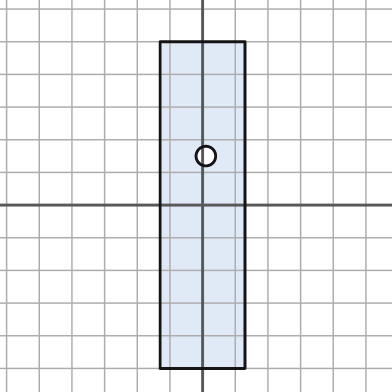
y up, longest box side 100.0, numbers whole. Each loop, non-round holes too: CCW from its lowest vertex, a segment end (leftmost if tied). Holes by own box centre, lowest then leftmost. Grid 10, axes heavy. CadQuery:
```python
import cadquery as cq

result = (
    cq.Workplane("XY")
    .moveTo(-13.0, -50.0)
    .lineTo(13.0, -50.0)
    .lineTo(13.0, 50.0)
    .lineTo(-13.0, 50.0)
    .close()
    .moveTo(1.0, 15.0)
    .circle(3.0)
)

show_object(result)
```